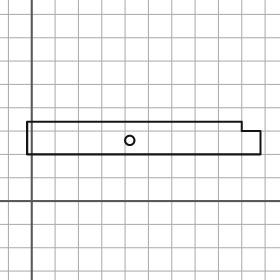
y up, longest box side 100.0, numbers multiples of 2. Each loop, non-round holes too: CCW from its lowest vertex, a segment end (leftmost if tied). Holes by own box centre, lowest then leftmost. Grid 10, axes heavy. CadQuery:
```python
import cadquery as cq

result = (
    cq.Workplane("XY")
    .moveTo(-2.0, 20.0)
    .lineTo(98.0, 20.0)
    .lineTo(98.0, 30.0)
    .lineTo(90.0, 30.0)
    .lineTo(90.0, 34.0)
    .lineTo(-2.0, 34.0)
    .close()
    .moveTo(42.0, 26.0)
    .circle(2.0)
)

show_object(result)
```